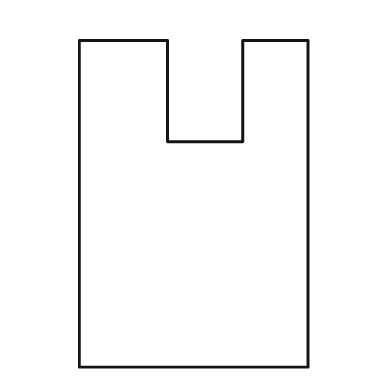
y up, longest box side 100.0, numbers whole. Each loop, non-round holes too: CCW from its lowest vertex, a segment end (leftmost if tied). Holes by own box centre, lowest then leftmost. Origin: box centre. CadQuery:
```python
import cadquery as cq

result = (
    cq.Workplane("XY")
    .moveTo(-35.0, -50.0)
    .lineTo(35.0, -50.0)
    .lineTo(35.0, 50.0)
    .lineTo(15.0, 50.0)
    .lineTo(15.0, 19.0)
    .lineTo(-8.0, 19.0)
    .lineTo(-8.0, 50.0)
    .lineTo(-35.0, 50.0)
    .close()
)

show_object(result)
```